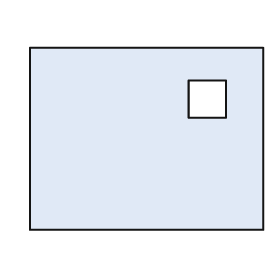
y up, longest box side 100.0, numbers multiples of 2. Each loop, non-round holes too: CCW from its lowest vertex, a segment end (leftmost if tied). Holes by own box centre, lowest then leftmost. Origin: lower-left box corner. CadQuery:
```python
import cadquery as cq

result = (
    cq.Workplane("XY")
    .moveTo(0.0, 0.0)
    .lineTo(100.0, 0.0)
    .lineTo(100.0, 78.0)
    .lineTo(0.0, 78.0)
    .close()
    .moveTo(68.0, 48.0)
    .lineTo(84.0, 48.0)
    .lineTo(84.0, 64.0)
    .lineTo(68.0, 64.0)
    .close()
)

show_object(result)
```